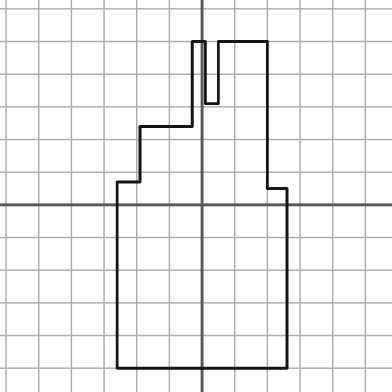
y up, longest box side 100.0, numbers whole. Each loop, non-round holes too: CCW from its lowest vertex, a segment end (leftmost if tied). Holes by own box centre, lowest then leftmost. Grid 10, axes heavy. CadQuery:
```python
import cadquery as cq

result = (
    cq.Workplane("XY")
    .moveTo(-26.0, -50.0)
    .lineTo(26.0, -50.0)
    .lineTo(26.0, 5.0)
    .lineTo(20.0, 5.0)
    .lineTo(20.0, 50.0)
    .lineTo(5.0, 50.0)
    .lineTo(5.0, 31.0)
    .lineTo(1.0, 31.0)
    .lineTo(1.0, 50.0)
    .lineTo(-3.0, 50.0)
    .lineTo(-3.0, 24.0)
    .lineTo(-19.0, 24.0)
    .lineTo(-19.0, 7.0)
    .lineTo(-26.0, 7.0)
    .close()
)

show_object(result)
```